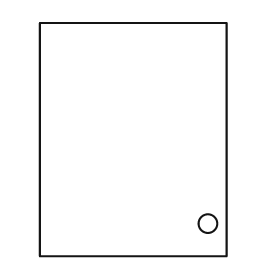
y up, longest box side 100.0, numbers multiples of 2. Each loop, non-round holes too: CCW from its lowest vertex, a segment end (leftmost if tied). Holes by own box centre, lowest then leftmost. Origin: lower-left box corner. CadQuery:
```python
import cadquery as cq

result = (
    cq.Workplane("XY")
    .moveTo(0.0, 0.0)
    .lineTo(80.0, 0.0)
    .lineTo(80.0, 100.0)
    .lineTo(0.0, 100.0)
    .close()
    .moveTo(72.0, 14.0)
    .circle(4.0)
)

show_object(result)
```